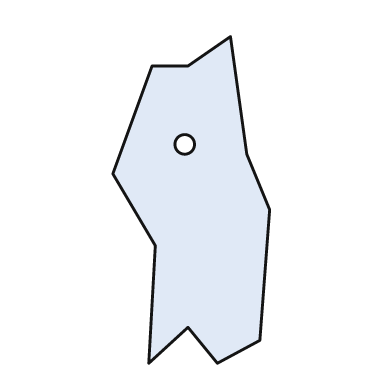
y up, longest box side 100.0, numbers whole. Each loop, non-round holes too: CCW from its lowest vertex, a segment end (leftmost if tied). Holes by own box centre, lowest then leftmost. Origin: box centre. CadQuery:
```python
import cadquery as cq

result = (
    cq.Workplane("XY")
    .moveTo(-13.0, -50.0)
    .lineTo(-1.0, -39.0)
    .lineTo(8.0, -50.0)
    .lineTo(21.0, -43.0)
    .lineTo(24.0, -3.0)
    .lineTo(17.0, 14.0)
    .lineTo(12.0, 50.0)
    .lineTo(-1.0, 41.0)
    .lineTo(-12.0, 41.0)
    .lineTo(-24.0, 8.0)
    .lineTo(-11.0, -14.0)
    .close()
    .moveTo(-2.0, 17.0)
    .circle(3.0)
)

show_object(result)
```